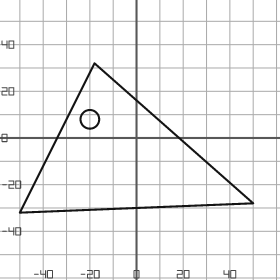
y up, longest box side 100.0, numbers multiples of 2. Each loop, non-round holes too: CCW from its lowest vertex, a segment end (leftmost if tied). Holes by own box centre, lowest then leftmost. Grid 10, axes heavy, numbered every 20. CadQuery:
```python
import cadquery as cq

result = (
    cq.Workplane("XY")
    .moveTo(-50.0, -32.0)
    .lineTo(50.0, -28.0)
    .lineTo(-18.0, 32.0)
    .close()
    .moveTo(-20.0, 8.0)
    .circle(4.0)
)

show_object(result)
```